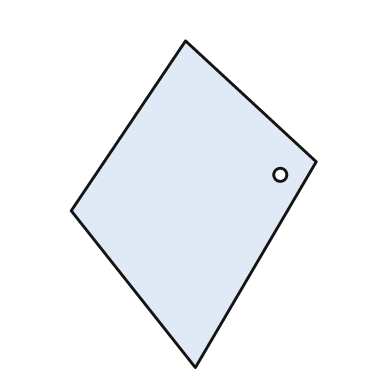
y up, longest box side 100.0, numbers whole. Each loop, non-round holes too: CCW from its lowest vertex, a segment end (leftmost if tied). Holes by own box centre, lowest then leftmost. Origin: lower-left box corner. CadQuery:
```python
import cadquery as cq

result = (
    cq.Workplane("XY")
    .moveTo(38.0, 0.0)
    .lineTo(75.0, 63.0)
    .lineTo(35.0, 100.0)
    .lineTo(0.0, 48.0)
    .close()
    .moveTo(64.0, 59.0)
    .circle(2.0)
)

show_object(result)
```